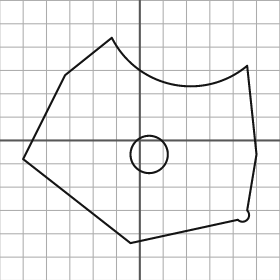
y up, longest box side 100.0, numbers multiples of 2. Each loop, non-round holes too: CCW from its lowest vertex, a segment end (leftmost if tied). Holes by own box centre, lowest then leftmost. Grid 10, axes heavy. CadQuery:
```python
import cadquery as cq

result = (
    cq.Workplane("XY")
    .moveTo(-4.0, -44.0)
    .lineTo(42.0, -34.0)
    .threePointArc((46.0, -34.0), (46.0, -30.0))
    .lineTo(50.0, -6.0)
    .lineTo(46.0, 32.0)
    .threePointArc((14.0, 24.0), (-12.0, 44.0))
    .lineTo(-32.0, 28.0)
    .lineTo(-50.0, -8.0)
    .close()
    .moveTo(4.0, -6.0)
    .circle(8.0)
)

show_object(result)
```